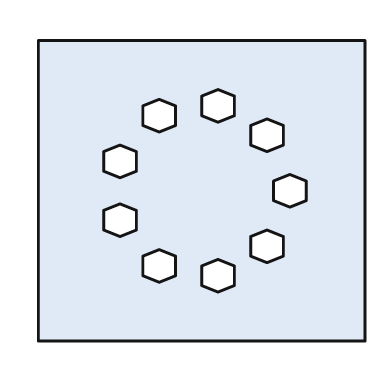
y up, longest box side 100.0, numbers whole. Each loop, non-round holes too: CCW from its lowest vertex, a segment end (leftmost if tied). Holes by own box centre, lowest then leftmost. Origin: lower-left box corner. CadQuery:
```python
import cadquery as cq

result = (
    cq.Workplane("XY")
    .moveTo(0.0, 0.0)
    .lineTo(100.0, 0.0)
    .lineTo(100.0, 92.0)
    .lineTo(0.0, 92.0)
    .close()
    .moveTo(55.0, 15.0)
    .lineTo(60.0, 17.0)
    .lineTo(60.0, 23.0)
    .lineTo(55.0, 25.0)
    .lineTo(50.0, 23.0)
    .lineTo(50.0, 17.0)
    .close()
    .moveTo(37.0, 18.0)
    .lineTo(42.0, 20.0)
    .lineTo(42.0, 26.0)
    .lineTo(37.0, 28.0)
    .lineTo(32.0, 26.0)
    .lineTo(32.0, 20.0)
    .close()
    .moveTo(70.0, 24.0)
    .lineTo(75.0, 26.0)
    .lineTo(75.0, 32.0)
    .lineTo(70.0, 34.0)
    .lineTo(65.0, 32.0)
    .lineTo(65.0, 26.0)
    .close()
    .moveTo(25.0, 32.0)
    .lineTo(30.0, 34.0)
    .lineTo(30.0, 40.0)
    .lineTo(25.0, 42.0)
    .lineTo(20.0, 40.0)
    .lineTo(20.0, 34.0)
    .close()
    .moveTo(77.0, 41.0)
    .lineTo(82.0, 43.0)
    .lineTo(82.0, 49.0)
    .lineTo(77.0, 51.0)
    .lineTo(72.0, 49.0)
    .lineTo(72.0, 43.0)
    .close()
    .moveTo(25.0, 50.0)
    .lineTo(30.0, 52.0)
    .lineTo(30.0, 58.0)
    .lineTo(25.0, 60.0)
    .lineTo(20.0, 58.0)
    .lineTo(20.0, 52.0)
    .close()
    .moveTo(70.0, 58.0)
    .lineTo(75.0, 60.0)
    .lineTo(75.0, 66.0)
    .lineTo(70.0, 68.0)
    .lineTo(65.0, 66.0)
    .lineTo(65.0, 60.0)
    .close()
    .moveTo(37.0, 64.0)
    .lineTo(42.0, 66.0)
    .lineTo(42.0, 72.0)
    .lineTo(37.0, 74.0)
    .lineTo(32.0, 72.0)
    .lineTo(32.0, 66.0)
    .close()
    .moveTo(55.0, 67.0)
    .lineTo(60.0, 69.0)
    .lineTo(60.0, 75.0)
    .lineTo(55.0, 77.0)
    .lineTo(50.0, 75.0)
    .lineTo(50.0, 69.0)
    .close()
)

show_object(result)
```